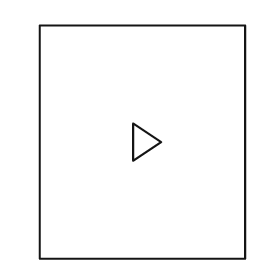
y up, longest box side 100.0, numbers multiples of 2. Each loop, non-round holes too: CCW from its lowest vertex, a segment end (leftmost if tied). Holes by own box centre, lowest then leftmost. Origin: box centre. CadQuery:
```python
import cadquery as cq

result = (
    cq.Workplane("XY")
    .moveTo(-44.0, -50.0)
    .lineTo(44.0, -50.0)
    .lineTo(44.0, 50.0)
    .lineTo(-44.0, 50.0)
    .close()
    .moveTo(-4.0, -8.0)
    .lineTo(8.0, 0.0)
    .lineTo(-4.0, 8.0)
    .close()
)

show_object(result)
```